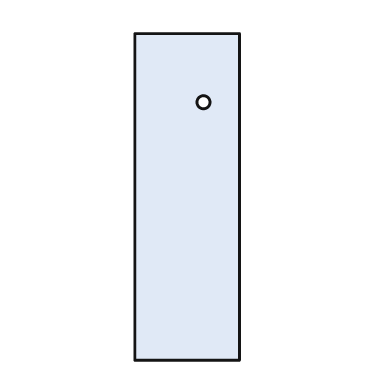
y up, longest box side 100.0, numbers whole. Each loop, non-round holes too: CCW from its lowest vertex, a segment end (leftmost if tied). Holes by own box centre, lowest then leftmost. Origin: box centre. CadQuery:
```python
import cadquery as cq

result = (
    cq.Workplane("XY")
    .moveTo(-16.0, -50.0)
    .lineTo(16.0, -50.0)
    .lineTo(16.0, 50.0)
    .lineTo(-16.0, 50.0)
    .close()
    .moveTo(5.0, 29.0)
    .circle(2.0)
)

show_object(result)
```